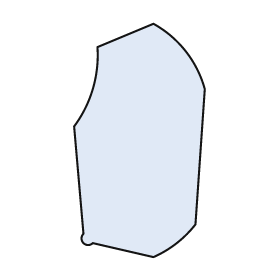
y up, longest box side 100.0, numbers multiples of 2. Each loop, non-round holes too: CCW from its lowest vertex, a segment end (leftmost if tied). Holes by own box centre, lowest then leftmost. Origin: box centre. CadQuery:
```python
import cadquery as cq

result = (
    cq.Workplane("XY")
    .moveTo(6.0, -50.0)
    .threePointArc((16.0, -44.0), (24.0, -36.0))
    .lineTo(28.0, 22.0)
    .threePointArc((20.0, 38.0), (6.0, 50.0))
    .lineTo(-18.0, 40.0)
    .threePointArc((-20.0, 22.0), (-28.0, 6.0))
    .lineTo(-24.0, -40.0)
    .threePointArc((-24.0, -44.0), (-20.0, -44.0))
    .close()
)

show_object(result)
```